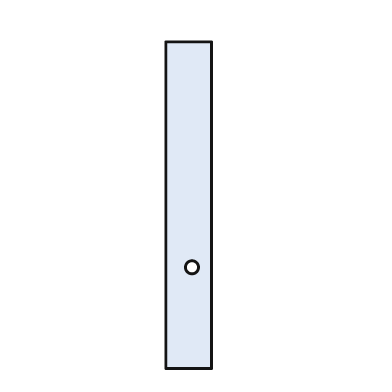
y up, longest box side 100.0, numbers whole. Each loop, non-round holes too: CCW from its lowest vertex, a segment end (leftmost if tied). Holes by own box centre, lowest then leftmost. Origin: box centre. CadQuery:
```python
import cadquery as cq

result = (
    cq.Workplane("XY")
    .moveTo(-7.0, -50.0)
    .lineTo(7.0, -50.0)
    .lineTo(7.0, 50.0)
    .lineTo(-7.0, 50.0)
    .close()
    .moveTo(1.0, -19.0)
    .circle(2.0)
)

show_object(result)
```